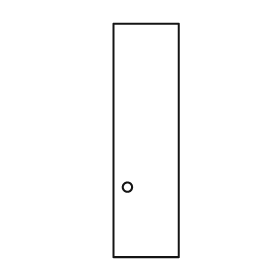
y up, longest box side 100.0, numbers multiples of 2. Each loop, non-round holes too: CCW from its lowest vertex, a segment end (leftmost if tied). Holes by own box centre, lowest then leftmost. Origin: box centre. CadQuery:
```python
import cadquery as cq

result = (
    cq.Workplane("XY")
    .moveTo(-14.0, -50.0)
    .lineTo(14.0, -50.0)
    .lineTo(14.0, 50.0)
    .lineTo(-14.0, 50.0)
    .close()
    .moveTo(-8.0, -20.0)
    .circle(2.0)
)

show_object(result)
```